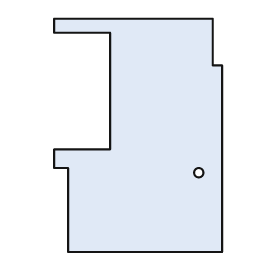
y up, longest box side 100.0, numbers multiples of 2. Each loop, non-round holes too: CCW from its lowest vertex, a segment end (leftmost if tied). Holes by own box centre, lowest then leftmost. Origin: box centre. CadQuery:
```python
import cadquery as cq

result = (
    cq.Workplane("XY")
    .moveTo(-30.0, -50.0)
    .lineTo(36.0, -50.0)
    .lineTo(36.0, 30.0)
    .lineTo(32.0, 30.0)
    .lineTo(32.0, 50.0)
    .lineTo(-36.0, 50.0)
    .lineTo(-36.0, 44.0)
    .lineTo(-12.0, 44.0)
    .lineTo(-12.0, -6.0)
    .lineTo(-36.0, -6.0)
    .lineTo(-36.0, -14.0)
    .lineTo(-30.0, -14.0)
    .close()
    .moveTo(26.0, -16.0)
    .circle(2.0)
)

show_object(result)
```